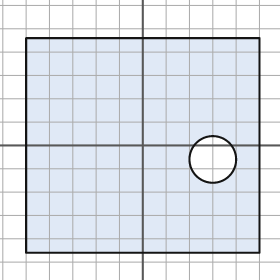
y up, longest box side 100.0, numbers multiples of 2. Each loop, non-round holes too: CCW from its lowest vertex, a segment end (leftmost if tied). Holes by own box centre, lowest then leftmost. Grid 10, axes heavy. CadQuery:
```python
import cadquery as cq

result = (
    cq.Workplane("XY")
    .moveTo(-50.0, -46.0)
    .lineTo(50.0, -46.0)
    .lineTo(50.0, 46.0)
    .lineTo(-50.0, 46.0)
    .close()
    .moveTo(30.0, -6.0)
    .circle(10.0)
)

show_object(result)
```